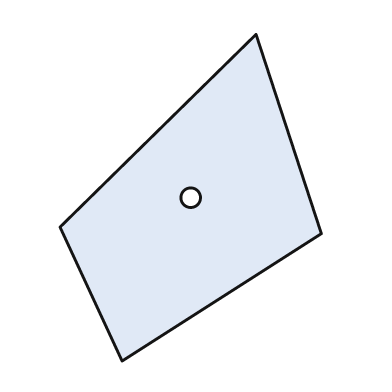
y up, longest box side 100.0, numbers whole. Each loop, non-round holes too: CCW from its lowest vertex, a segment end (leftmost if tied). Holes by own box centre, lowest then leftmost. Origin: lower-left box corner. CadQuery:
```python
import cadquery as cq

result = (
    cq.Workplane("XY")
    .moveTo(19.0, 0.0)
    .lineTo(80.0, 39.0)
    .lineTo(60.0, 100.0)
    .lineTo(0.0, 41.0)
    .close()
    .moveTo(40.0, 50.0)
    .circle(3.0)
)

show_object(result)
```